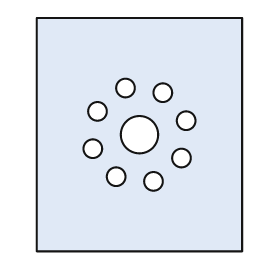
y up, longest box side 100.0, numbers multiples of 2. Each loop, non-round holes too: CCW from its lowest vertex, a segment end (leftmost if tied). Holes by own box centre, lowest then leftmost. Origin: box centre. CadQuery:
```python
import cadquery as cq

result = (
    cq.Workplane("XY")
    .moveTo(-44.0, -50.0)
    .lineTo(44.0, -50.0)
    .lineTo(44.0, 50.0)
    .lineTo(-44.0, 50.0)
    .close()
    .moveTo(6.0, -20.0)
    .circle(4.0)
    .moveTo(-10.0, -18.0)
    .circle(4.0)
    .moveTo(18.0, -10.0)
    .circle(4.0)
    .moveTo(-20.0, -6.0)
    .circle(4.0)
    .moveTo(0.0, 0.0)
    .circle(8.0)
    .moveTo(20.0, 6.0)
    .circle(4.0)
    .moveTo(-18.0, 10.0)
    .circle(4.0)
    .moveTo(10.0, 18.0)
    .circle(4.0)
    .moveTo(-6.0, 20.0)
    .circle(4.0)
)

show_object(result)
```